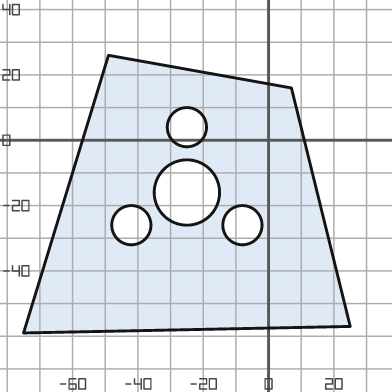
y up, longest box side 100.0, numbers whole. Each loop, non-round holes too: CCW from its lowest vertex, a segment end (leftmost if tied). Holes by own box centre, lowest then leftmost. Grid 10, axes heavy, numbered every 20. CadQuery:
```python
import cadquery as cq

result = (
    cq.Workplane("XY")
    .moveTo(-75.0, -59.0)
    .lineTo(25.0, -57.0)
    .lineTo(7.0, 16.0)
    .lineTo(-49.0, 26.0)
    .close()
    .moveTo(-42.0, -26.0)
    .circle(6.0)
    .moveTo(-8.0, -26.0)
    .circle(6.0)
    .moveTo(-25.0, -16.0)
    .circle(10.0)
    .moveTo(-25.0, 4.0)
    .circle(6.0)
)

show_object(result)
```